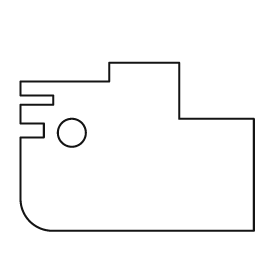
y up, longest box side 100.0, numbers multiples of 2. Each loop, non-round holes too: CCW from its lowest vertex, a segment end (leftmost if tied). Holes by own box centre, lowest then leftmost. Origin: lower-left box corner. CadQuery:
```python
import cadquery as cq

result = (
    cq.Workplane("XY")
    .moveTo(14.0, 0.0)
    .lineTo(100.0, 0.0)
    .lineTo(100.0, 48.0)
    .lineTo(68.0, 48.0)
    .lineTo(68.0, 72.0)
    .lineTo(38.0, 72.0)
    .lineTo(38.0, 64.0)
    .lineTo(0.0, 64.0)
    .lineTo(0.0, 58.0)
    .lineTo(14.0, 58.0)
    .lineTo(14.0, 54.0)
    .lineTo(0.0, 54.0)
    .lineTo(0.0, 46.0)
    .lineTo(10.0, 46.0)
    .lineTo(10.0, 40.0)
    .lineTo(0.0, 40.0)
    .lineTo(0.0, 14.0)
    .threePointArc((4.0, 4.0), (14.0, 0.0))
    .close()
    .moveTo(22.0, 42.0)
    .circle(6.0)
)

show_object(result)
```